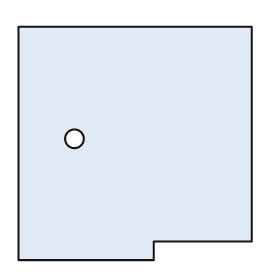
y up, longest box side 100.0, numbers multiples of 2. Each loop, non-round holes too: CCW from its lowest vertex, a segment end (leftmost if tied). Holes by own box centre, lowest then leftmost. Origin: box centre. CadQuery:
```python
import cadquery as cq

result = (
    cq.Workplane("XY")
    .moveTo(-50.0, -50.0)
    .lineTo(8.0, -50.0)
    .lineTo(8.0, -42.0)
    .lineTo(50.0, -42.0)
    .lineTo(50.0, 50.0)
    .lineTo(-50.0, 50.0)
    .close()
    .moveTo(-26.0, 2.0)
    .circle(4.0)
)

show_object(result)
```